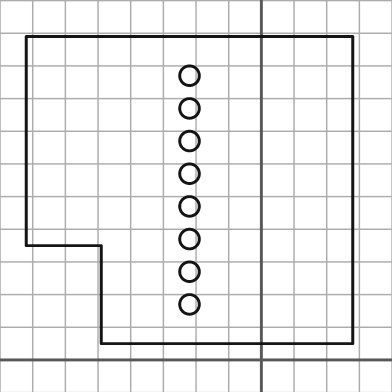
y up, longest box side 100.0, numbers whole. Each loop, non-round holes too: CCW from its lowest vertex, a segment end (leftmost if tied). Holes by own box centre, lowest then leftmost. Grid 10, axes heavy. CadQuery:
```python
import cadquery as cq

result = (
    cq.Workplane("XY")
    .moveTo(-49.0, 5.0)
    .lineTo(28.0, 5.0)
    .lineTo(28.0, 99.0)
    .lineTo(-72.0, 99.0)
    .lineTo(-72.0, 35.0)
    .lineTo(-49.0, 35.0)
    .close()
    .moveTo(-22.0, 17.0)
    .circle(3.0)
    .moveTo(-22.0, 27.0)
    .circle(3.0)
    .moveTo(-22.0, 37.0)
    .circle(3.0)
    .moveTo(-22.0, 47.0)
    .circle(3.0)
    .moveTo(-22.0, 57.0)
    .circle(3.0)
    .moveTo(-22.0, 67.0)
    .circle(3.0)
    .moveTo(-22.0, 77.0)
    .circle(3.0)
    .moveTo(-22.0, 87.0)
    .circle(3.0)
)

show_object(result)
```